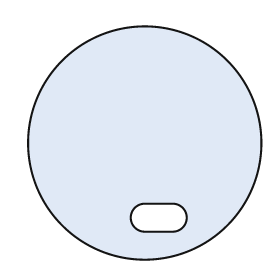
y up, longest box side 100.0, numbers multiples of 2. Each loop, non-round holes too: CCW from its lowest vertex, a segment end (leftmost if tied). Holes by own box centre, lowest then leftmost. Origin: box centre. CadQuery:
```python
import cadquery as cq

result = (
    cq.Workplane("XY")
    .moveTo(0.0, 0.0)
    .circle(50.0)
    .moveTo(0.0, -38.0)
    .lineTo(12.0, -38.0)
    .threePointArc((18.0, -32.0), (12.0, -26.0))
    .lineTo(0.0, -26.0)
    .threePointArc((-6.0, -32.0), (0.0, -38.0))
    .close()
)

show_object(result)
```